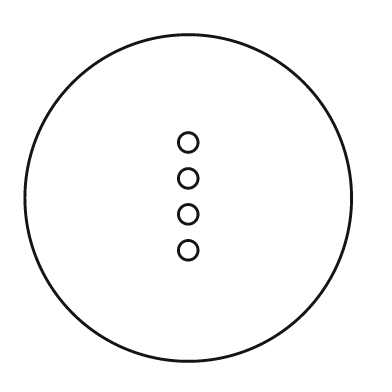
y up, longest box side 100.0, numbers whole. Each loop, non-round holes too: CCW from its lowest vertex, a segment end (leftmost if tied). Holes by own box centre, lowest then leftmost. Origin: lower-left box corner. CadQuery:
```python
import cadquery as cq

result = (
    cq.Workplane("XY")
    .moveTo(50.0, 50.0)
    .circle(50.0)
    .moveTo(50.0, 34.0)
    .circle(3.0)
    .moveTo(50.0, 45.0)
    .circle(3.0)
    .moveTo(50.0, 56.0)
    .circle(3.0)
    .moveTo(50.0, 67.0)
    .circle(3.0)
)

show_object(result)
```